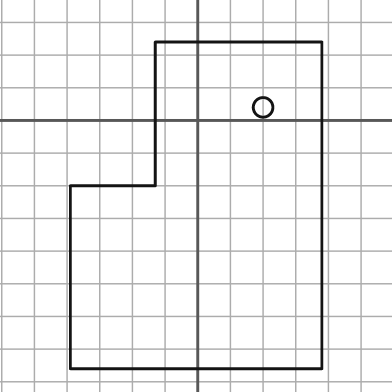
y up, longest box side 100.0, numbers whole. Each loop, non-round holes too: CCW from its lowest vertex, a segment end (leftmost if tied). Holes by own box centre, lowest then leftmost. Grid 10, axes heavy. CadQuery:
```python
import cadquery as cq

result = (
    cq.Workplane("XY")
    .moveTo(-39.0, -76.0)
    .lineTo(38.0, -76.0)
    .lineTo(38.0, 24.0)
    .lineTo(-13.0, 24.0)
    .lineTo(-13.0, -20.0)
    .lineTo(-39.0, -20.0)
    .close()
    .moveTo(20.0, 4.0)
    .circle(3.0)
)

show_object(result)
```